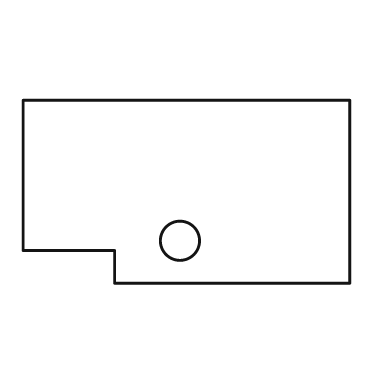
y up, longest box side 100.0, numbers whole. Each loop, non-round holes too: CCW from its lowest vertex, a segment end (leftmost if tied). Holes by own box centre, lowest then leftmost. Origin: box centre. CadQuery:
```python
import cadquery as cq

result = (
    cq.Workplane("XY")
    .moveTo(-22.0, -28.0)
    .lineTo(50.0, -28.0)
    .lineTo(50.0, 28.0)
    .lineTo(-50.0, 28.0)
    .lineTo(-50.0, -18.0)
    .lineTo(-22.0, -18.0)
    .close()
    .moveTo(-2.0, -15.0)
    .circle(6.0)
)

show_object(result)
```